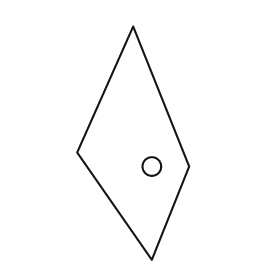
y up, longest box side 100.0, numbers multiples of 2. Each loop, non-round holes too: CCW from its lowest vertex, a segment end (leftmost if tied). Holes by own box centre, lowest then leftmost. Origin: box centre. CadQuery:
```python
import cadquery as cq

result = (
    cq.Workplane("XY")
    .moveTo(8.0, -50.0)
    .lineTo(24.0, -10.0)
    .lineTo(0.0, 50.0)
    .lineTo(-24.0, -4.0)
    .close()
    .moveTo(8.0, -10.0)
    .circle(4.0)
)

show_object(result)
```